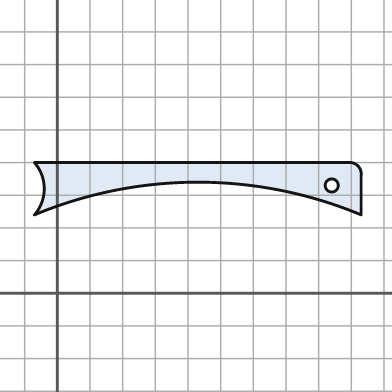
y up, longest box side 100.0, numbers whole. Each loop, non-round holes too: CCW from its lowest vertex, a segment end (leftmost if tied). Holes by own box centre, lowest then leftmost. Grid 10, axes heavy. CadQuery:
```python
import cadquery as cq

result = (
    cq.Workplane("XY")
    .moveTo(-7.0, 24.0)
    .threePointArc((43.0, 34.0), (93.0, 24.0))
    .lineTo(93.0, 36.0)
    .threePointArc((92.0, 39.0), (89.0, 40.0))
    .lineTo(-7.0, 40.0)
    .threePointArc((-4.0, 32.0), (-7.0, 24.0))
    .close()
    .moveTo(84.0, 33.0)
    .circle(2.0)
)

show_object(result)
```